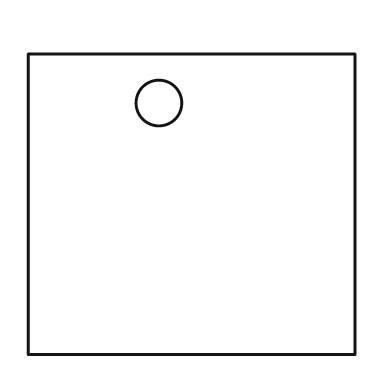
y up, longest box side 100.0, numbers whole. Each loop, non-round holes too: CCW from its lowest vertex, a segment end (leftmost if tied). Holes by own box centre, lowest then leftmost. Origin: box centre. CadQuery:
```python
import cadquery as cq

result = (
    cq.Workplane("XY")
    .moveTo(-50.0, -46.0)
    .lineTo(50.0, -46.0)
    .lineTo(50.0, 46.0)
    .lineTo(-50.0, 46.0)
    .close()
    .moveTo(-10.0, 31.0)
    .circle(7.0)
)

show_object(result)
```